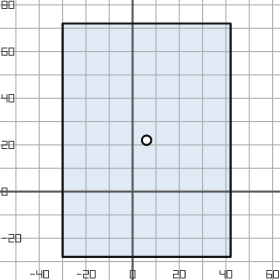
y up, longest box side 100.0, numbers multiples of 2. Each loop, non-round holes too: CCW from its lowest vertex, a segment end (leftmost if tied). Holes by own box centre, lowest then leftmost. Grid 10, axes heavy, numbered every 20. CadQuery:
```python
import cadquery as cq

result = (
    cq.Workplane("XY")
    .moveTo(-30.0, -28.0)
    .lineTo(42.0, -28.0)
    .lineTo(42.0, 72.0)
    .lineTo(-30.0, 72.0)
    .close()
    .moveTo(6.0, 22.0)
    .circle(2.0)
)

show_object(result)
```